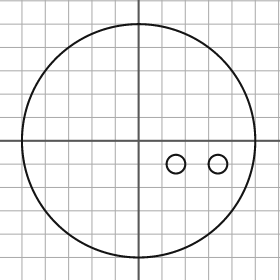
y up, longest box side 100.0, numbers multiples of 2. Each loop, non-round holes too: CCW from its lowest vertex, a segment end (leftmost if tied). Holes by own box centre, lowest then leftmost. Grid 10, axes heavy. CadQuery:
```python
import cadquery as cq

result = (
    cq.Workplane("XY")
    .moveTo(0.0, 0.0)
    .circle(50.0)
    .moveTo(16.0, -10.0)
    .circle(4.0)
    .moveTo(34.0, -10.0)
    .circle(4.0)
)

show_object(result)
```